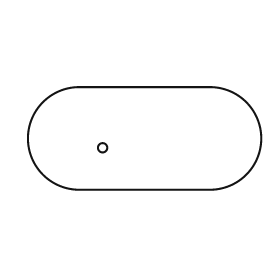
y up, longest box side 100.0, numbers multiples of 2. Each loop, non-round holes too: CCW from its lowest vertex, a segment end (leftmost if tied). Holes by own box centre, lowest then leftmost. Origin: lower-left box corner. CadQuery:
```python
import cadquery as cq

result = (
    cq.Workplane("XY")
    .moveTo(22.0, 0.0)
    .lineTo(78.0, 0.0)
    .threePointArc((100.0, 22.0), (78.0, 44.0))
    .lineTo(22.0, 44.0)
    .threePointArc((0.0, 22.0), (22.0, 0.0))
    .close()
    .moveTo(32.0, 18.0)
    .circle(2.0)
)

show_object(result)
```